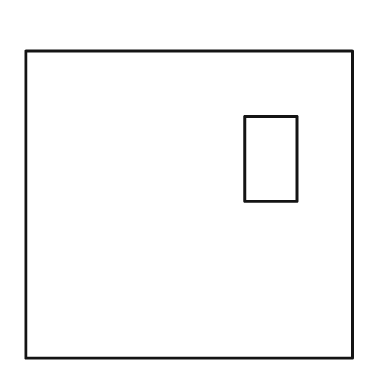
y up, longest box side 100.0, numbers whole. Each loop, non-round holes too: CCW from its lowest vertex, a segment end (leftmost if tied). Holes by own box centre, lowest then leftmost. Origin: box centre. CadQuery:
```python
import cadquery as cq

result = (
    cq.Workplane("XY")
    .moveTo(-50.0, -47.0)
    .lineTo(50.0, -47.0)
    .lineTo(50.0, 47.0)
    .lineTo(-50.0, 47.0)
    .close()
    .moveTo(17.0, 1.0)
    .lineTo(33.0, 1.0)
    .lineTo(33.0, 27.0)
    .lineTo(17.0, 27.0)
    .close()
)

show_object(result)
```